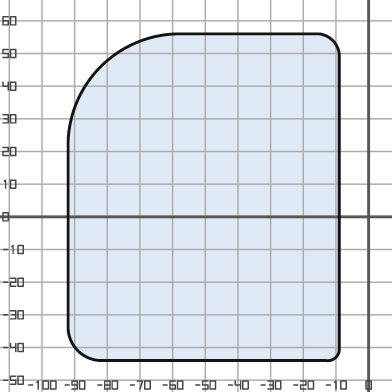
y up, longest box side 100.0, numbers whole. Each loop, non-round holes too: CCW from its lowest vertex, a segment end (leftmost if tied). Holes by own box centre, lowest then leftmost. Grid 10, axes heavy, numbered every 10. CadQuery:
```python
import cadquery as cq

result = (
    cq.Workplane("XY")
    .moveTo(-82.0, -44.0)
    .lineTo(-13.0, -44.0)
    .threePointArc((-10.0, -43.0), (-9.0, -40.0))
    .lineTo(-9.0, 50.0)
    .threePointArc((-11.0, 54.0), (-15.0, 56.0))
    .lineTo(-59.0, 56.0)
    .threePointArc((-82.0, 46.0), (-92.0, 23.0))
    .lineTo(-92.0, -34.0)
    .threePointArc((-89.0, -41.0), (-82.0, -44.0))
    .close()
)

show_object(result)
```